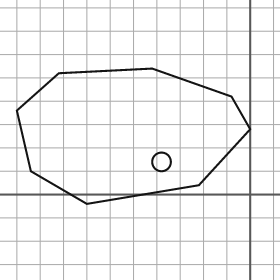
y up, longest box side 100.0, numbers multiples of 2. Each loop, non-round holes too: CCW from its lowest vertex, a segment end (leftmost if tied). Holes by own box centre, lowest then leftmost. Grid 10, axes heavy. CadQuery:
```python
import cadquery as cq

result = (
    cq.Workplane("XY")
    .moveTo(-70.0, -4.0)
    .lineTo(-22.0, 4.0)
    .lineTo(0.0, 28.0)
    .lineTo(-8.0, 42.0)
    .lineTo(-42.0, 54.0)
    .lineTo(-82.0, 52.0)
    .lineTo(-100.0, 36.0)
    .lineTo(-94.0, 10.0)
    .close()
    .moveTo(-38.0, 14.0)
    .circle(4.0)
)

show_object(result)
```